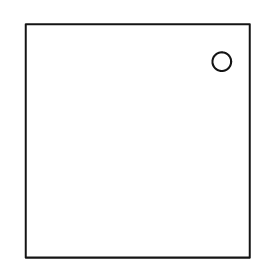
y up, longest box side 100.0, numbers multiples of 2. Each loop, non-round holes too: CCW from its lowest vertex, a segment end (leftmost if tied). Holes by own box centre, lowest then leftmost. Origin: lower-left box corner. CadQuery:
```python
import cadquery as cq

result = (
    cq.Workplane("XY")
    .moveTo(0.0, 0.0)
    .lineTo(96.0, 0.0)
    .lineTo(96.0, 100.0)
    .lineTo(0.0, 100.0)
    .close()
    .moveTo(84.0, 84.0)
    .circle(4.0)
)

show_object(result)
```